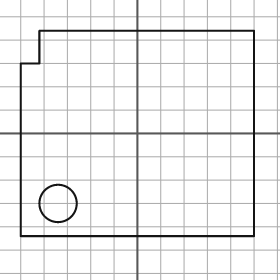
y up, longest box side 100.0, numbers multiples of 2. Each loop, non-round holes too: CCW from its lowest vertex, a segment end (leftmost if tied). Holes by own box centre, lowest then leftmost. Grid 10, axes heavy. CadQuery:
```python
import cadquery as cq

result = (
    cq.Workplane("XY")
    .moveTo(-50.0, -44.0)
    .lineTo(50.0, -44.0)
    .lineTo(50.0, 44.0)
    .lineTo(-42.0, 44.0)
    .lineTo(-42.0, 30.0)
    .lineTo(-50.0, 30.0)
    .close()
    .moveTo(-34.0, -30.0)
    .circle(8.0)
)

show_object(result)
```